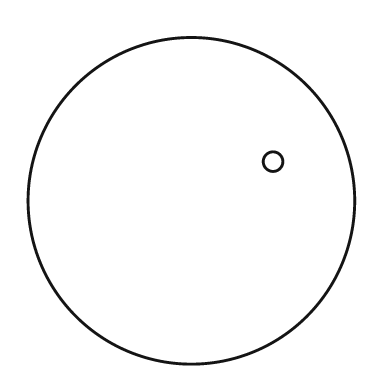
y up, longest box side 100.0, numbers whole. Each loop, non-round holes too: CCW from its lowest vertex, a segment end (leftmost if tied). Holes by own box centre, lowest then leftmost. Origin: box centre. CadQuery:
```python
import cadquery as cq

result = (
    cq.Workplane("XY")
    .moveTo(0.0, 0.0)
    .circle(50.0)
    .moveTo(25.0, 12.0)
    .circle(3.0)
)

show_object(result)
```